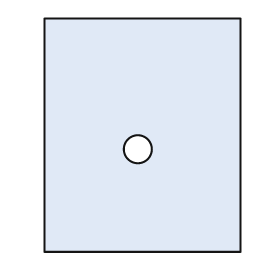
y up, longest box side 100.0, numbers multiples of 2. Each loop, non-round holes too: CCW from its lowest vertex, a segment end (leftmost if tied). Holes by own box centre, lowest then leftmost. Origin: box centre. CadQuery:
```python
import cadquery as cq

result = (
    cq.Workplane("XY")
    .moveTo(-42.0, -50.0)
    .lineTo(42.0, -50.0)
    .lineTo(42.0, 50.0)
    .lineTo(-42.0, 50.0)
    .close()
    .moveTo(-2.0, -6.0)
    .circle(6.0)
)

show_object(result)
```